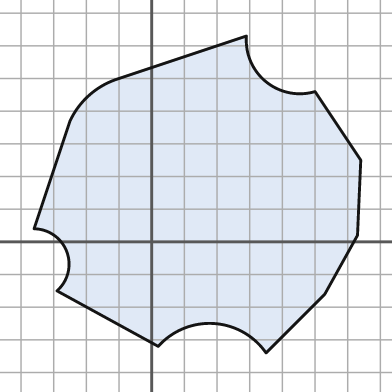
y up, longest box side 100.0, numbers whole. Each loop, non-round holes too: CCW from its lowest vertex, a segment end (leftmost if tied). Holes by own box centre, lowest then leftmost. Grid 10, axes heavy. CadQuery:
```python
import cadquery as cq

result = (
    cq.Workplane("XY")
    .moveTo(35.0, -34.0)
    .lineTo(53.0, -16.0)
    .lineTo(63.0, 2.0)
    .lineTo(64.0, 25.0)
    .lineTo(50.0, 46.0)
    .threePointArc((35.0, 49.0), (29.0, 63.0))
    .lineTo(-10.0, 50.0)
    .threePointArc((-19.0, 45.0), (-25.0, 37.0))
    .lineTo(-36.0, 4.0)
    .threePointArc((-26.0, -3.0), (-29.0, -15.0))
    .lineTo(2.0, -32.0)
    .threePointArc((19.0, -25.0), (35.0, -34.0))
    .close()
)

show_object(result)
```